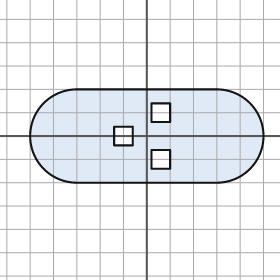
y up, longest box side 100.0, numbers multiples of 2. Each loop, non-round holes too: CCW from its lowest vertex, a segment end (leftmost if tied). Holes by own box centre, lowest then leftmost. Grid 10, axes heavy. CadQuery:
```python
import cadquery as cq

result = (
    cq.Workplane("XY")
    .moveTo(-30.0, -20.0)
    .lineTo(30.0, -20.0)
    .threePointArc((50.0, 0.0), (30.0, 20.0))
    .lineTo(-30.0, 20.0)
    .threePointArc((-50.0, 0.0), (-30.0, -20.0))
    .close()
    .moveTo(2.0, -14.0)
    .lineTo(10.0, -14.0)
    .lineTo(10.0, -6.0)
    .lineTo(2.0, -6.0)
    .close()
    .moveTo(-14.0, -4.0)
    .lineTo(-6.0, -4.0)
    .lineTo(-6.0, 4.0)
    .lineTo(-14.0, 4.0)
    .close()
    .moveTo(2.0, 6.0)
    .lineTo(10.0, 6.0)
    .lineTo(10.0, 14.0)
    .lineTo(2.0, 14.0)
    .close()
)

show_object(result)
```